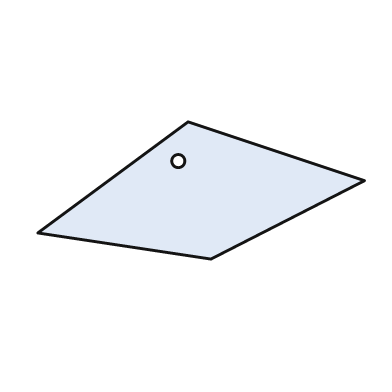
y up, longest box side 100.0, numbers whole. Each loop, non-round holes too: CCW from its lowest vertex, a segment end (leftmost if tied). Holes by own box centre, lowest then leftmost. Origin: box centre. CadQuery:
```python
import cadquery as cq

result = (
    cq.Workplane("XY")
    .moveTo(3.0, -21.0)
    .lineTo(50.0, 3.0)
    .lineTo(-4.0, 21.0)
    .lineTo(-50.0, -13.0)
    .close()
    .moveTo(-7.0, 9.0)
    .circle(2.0)
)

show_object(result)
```